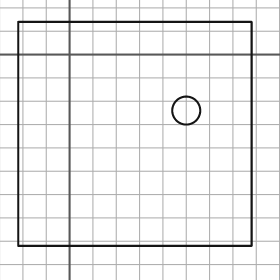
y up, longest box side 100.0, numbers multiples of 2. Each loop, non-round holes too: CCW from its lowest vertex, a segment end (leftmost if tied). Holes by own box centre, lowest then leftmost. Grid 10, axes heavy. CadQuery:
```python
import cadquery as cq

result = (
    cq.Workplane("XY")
    .moveTo(-22.0, -82.0)
    .lineTo(78.0, -82.0)
    .lineTo(78.0, 14.0)
    .lineTo(-22.0, 14.0)
    .close()
    .moveTo(50.0, -24.0)
    .circle(6.0)
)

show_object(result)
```